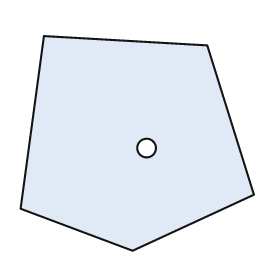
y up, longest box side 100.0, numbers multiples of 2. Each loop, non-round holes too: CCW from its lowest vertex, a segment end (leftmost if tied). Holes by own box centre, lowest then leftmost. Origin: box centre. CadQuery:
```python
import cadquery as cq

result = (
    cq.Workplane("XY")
    .moveTo(-2.0, -46.0)
    .lineTo(50.0, -22.0)
    .lineTo(30.0, 42.0)
    .lineTo(-40.0, 46.0)
    .lineTo(-50.0, -28.0)
    .close()
    .moveTo(4.0, -2.0)
    .circle(4.0)
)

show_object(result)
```